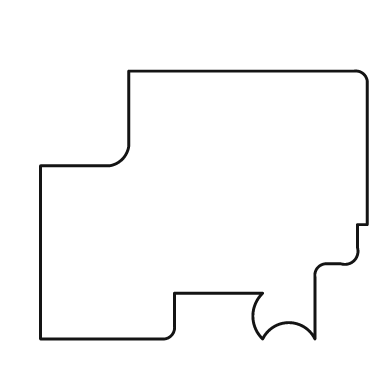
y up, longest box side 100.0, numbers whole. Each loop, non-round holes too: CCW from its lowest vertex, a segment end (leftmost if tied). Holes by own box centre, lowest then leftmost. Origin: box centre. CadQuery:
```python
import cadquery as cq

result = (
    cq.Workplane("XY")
    .moveTo(-50.0, -41.0)
    .lineTo(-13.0, -41.0)
    .threePointArc((-10.0, -40.0), (-9.0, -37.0))
    .lineTo(-9.0, -27.0)
    .lineTo(18.0, -27.0)
    .threePointArc((15.0, -34.0), (18.0, -41.0))
    .threePointArc((26.0, -36.0), (34.0, -41.0))
    .lineTo(34.0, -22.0)
    .threePointArc((35.0, -19.0), (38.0, -18.0))
    .lineTo(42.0, -18.0)
    .threePointArc((46.0, -17.0), (47.0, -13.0))
    .lineTo(47.0, -6.0)
    .lineTo(50.0, -6.0)
    .lineTo(50.0, 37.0)
    .threePointArc((49.0, 40.0), (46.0, 41.0))
    .lineTo(-23.0, 41.0)
    .lineTo(-23.0, 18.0)
    .threePointArc((-25.0, 14.0), (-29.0, 12.0))
    .lineTo(-50.0, 12.0)
    .close()
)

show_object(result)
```